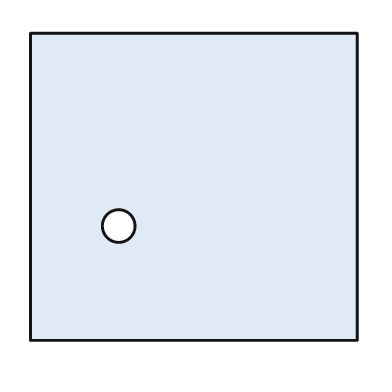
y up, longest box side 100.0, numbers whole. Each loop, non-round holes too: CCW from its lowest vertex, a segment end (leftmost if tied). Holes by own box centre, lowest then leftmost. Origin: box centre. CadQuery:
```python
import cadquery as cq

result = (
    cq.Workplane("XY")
    .moveTo(-50.0, -47.0)
    .lineTo(50.0, -47.0)
    .lineTo(50.0, 47.0)
    .lineTo(-50.0, 47.0)
    .close()
    .moveTo(-23.0, -12.0)
    .circle(5.0)
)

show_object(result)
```